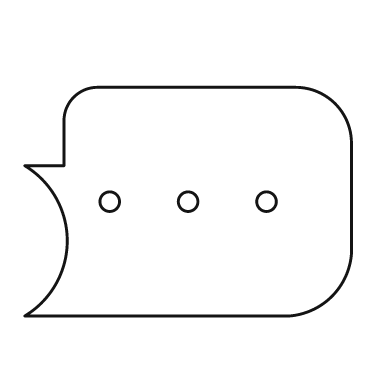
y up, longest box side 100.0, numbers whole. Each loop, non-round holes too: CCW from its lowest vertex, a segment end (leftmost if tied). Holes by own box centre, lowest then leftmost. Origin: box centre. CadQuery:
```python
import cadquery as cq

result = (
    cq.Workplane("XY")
    .moveTo(-50.0, -35.0)
    .lineTo(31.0, -35.0)
    .threePointArc((44.0, -29.0), (50.0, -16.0))
    .lineTo(50.0, 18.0)
    .threePointArc((45.0, 30.0), (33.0, 35.0))
    .lineTo(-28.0, 35.0)
    .threePointArc((-35.0, 32.0), (-38.0, 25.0))
    .lineTo(-38.0, 11.0)
    .lineTo(-50.0, 11.0)
    .threePointArc((-37.0, -12.0), (-50.0, -35.0))
    .close()
    .moveTo(-24.0, 0.0)
    .circle(3.0)
    .moveTo(0.0, 0.0)
    .circle(3.0)
    .moveTo(24.0, 0.0)
    .circle(3.0)
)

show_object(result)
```